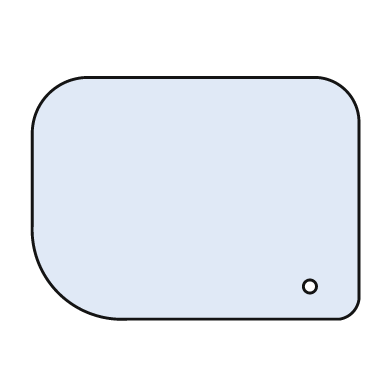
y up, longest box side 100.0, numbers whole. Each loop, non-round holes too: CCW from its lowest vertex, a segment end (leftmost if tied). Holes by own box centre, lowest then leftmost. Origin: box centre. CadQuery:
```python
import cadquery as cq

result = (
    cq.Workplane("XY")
    .moveTo(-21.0, -37.0)
    .lineTo(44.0, -37.0)
    .threePointArc((48.0, -35.0), (50.0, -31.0))
    .lineTo(50.0, 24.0)
    .threePointArc((46.0, 33.0), (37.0, 37.0))
    .lineTo(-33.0, 37.0)
    .threePointArc((-45.0, 32.0), (-50.0, 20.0))
    .lineTo(-50.0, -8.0)
    .threePointArc((-42.0, -29.0), (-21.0, -37.0))
    .close()
    .moveTo(35.0, -27.0)
    .circle(2.0)
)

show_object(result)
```